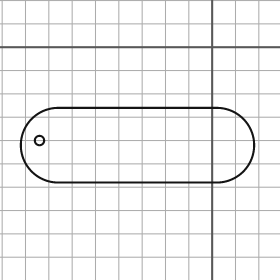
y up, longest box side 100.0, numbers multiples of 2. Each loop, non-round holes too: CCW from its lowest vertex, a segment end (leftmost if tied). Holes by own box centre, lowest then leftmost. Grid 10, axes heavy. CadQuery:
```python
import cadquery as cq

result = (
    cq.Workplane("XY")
    .moveTo(-66.0, -58.0)
    .lineTo(2.0, -58.0)
    .threePointArc((18.0, -42.0), (2.0, -26.0))
    .lineTo(-66.0, -26.0)
    .threePointArc((-82.0, -42.0), (-66.0, -58.0))
    .close()
    .moveTo(-74.0, -40.0)
    .circle(2.0)
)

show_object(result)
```